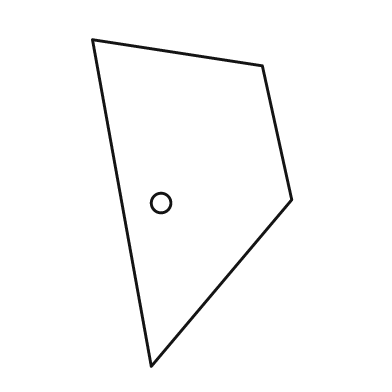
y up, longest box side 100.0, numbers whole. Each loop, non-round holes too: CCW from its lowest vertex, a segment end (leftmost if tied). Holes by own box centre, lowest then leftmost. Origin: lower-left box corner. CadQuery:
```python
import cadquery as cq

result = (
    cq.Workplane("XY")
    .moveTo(18.0, 0.0)
    .lineTo(61.0, 51.0)
    .lineTo(52.0, 92.0)
    .lineTo(0.0, 100.0)
    .close()
    .moveTo(21.0, 50.0)
    .circle(3.0)
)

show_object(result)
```